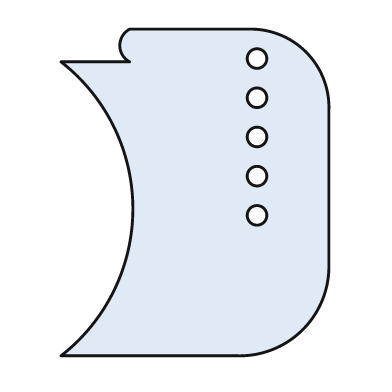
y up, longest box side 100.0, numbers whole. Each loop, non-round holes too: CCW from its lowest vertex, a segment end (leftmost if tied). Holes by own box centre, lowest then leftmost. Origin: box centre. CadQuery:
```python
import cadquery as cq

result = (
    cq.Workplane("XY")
    .moveTo(-41.0, -50.0)
    .lineTo(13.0, -50.0)
    .threePointArc((33.0, -42.0), (41.0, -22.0))
    .lineTo(41.0, 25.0)
    .threePointArc((34.0, 43.0), (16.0, 50.0))
    .lineTo(-20.0, 50.0)
    .threePointArc((-23.0, 45.0), (-20.0, 40.0))
    .lineTo(-41.0, 40.0)
    .threePointArc((-19.0, -5.0), (-41.0, -50.0))
    .close()
    .moveTo(19.0, -7.0)
    .circle(3.0)
    .moveTo(19.0, 5.0)
    .circle(3.0)
    .moveTo(19.0, 17.0)
    .circle(3.0)
    .moveTo(19.0, 29.0)
    .circle(3.0)
    .moveTo(19.0, 41.0)
    .circle(3.0)
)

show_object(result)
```